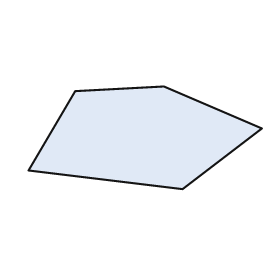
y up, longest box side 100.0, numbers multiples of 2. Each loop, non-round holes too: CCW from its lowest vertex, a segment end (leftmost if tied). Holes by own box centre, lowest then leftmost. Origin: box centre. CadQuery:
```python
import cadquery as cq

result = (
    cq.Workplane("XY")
    .moveTo(16.0, -22.0)
    .lineTo(50.0, 4.0)
    .lineTo(8.0, 22.0)
    .lineTo(-30.0, 20.0)
    .lineTo(-50.0, -14.0)
    .close()
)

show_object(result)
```